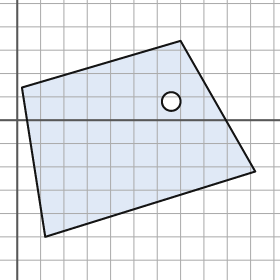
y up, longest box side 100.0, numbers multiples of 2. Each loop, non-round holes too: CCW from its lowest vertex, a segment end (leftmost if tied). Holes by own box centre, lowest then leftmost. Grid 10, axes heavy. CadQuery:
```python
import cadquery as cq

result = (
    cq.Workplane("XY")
    .moveTo(12.0, -50.0)
    .lineTo(102.0, -22.0)
    .lineTo(70.0, 34.0)
    .lineTo(2.0, 14.0)
    .close()
    .moveTo(66.0, 8.0)
    .circle(4.0)
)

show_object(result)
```